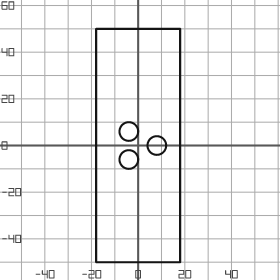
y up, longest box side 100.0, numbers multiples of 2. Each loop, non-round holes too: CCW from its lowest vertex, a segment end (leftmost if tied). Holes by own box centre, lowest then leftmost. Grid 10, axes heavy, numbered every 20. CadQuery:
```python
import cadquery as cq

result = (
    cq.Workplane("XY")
    .moveTo(-18.0, -50.0)
    .lineTo(18.0, -50.0)
    .lineTo(18.0, 50.0)
    .lineTo(-18.0, 50.0)
    .close()
    .moveTo(-4.0, -6.0)
    .circle(4.0)
    .moveTo(8.0, 0.0)
    .circle(4.0)
    .moveTo(-4.0, 6.0)
    .circle(4.0)
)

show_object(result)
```